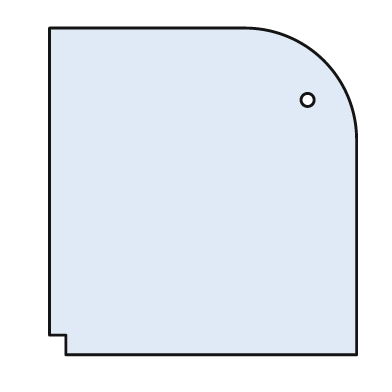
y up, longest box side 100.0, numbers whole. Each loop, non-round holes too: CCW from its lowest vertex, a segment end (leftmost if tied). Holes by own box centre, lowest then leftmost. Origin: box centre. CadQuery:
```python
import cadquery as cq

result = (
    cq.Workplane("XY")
    .moveTo(-42.0, -50.0)
    .lineTo(47.0, -50.0)
    .lineTo(47.0, 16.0)
    .threePointArc((37.0, 40.0), (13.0, 50.0))
    .lineTo(-47.0, 50.0)
    .lineTo(-47.0, -44.0)
    .lineTo(-42.0, -44.0)
    .close()
    .moveTo(32.0, 28.0)
    .circle(2.0)
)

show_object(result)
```